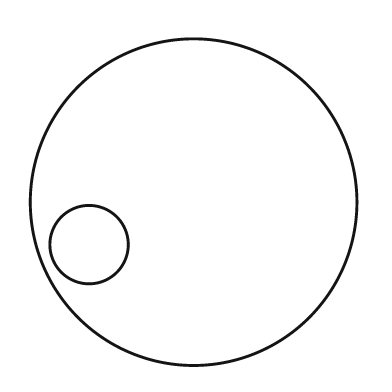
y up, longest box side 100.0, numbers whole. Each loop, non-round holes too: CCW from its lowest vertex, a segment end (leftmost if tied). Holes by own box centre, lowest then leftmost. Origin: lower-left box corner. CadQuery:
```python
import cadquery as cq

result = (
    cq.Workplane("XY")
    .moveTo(50.0, 50.0)
    .circle(50.0)
    .moveTo(18.0, 37.0)
    .circle(12.0)
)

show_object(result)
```